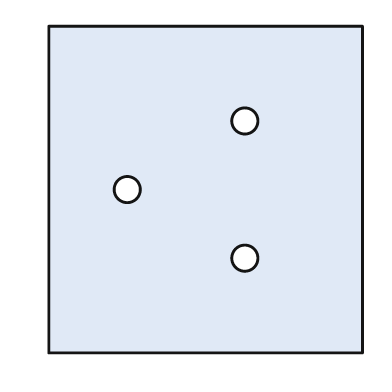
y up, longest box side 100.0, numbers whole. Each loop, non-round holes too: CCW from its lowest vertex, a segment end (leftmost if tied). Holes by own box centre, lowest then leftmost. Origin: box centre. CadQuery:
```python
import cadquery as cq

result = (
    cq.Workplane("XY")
    .moveTo(-48.0, -50.0)
    .lineTo(48.0, -50.0)
    .lineTo(48.0, 50.0)
    .lineTo(-48.0, 50.0)
    .close()
    .moveTo(12.0, -21.0)
    .circle(4.0)
    .moveTo(-24.0, 0.0)
    .circle(4.0)
    .moveTo(12.0, 21.0)
    .circle(4.0)
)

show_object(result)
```